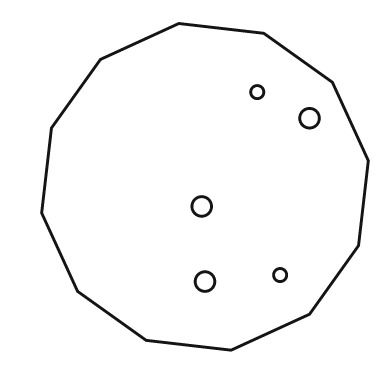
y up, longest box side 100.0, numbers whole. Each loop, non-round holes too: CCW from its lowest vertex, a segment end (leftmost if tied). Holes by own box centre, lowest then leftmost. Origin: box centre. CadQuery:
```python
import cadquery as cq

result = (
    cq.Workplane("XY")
    .moveTo(8.0, -50.0)
    .lineTo(32.0, -39.0)
    .lineTo(47.0, -18.0)
    .lineTo(50.0, 8.0)
    .lineTo(39.0, 32.0)
    .lineTo(18.0, 47.0)
    .lineTo(-8.0, 50.0)
    .lineTo(-32.0, 39.0)
    .lineTo(-47.0, 18.0)
    .lineTo(-50.0, -8.0)
    .lineTo(-39.0, -32.0)
    .lineTo(-18.0, -47.0)
    .close()
    .moveTo(0.0, -29.0)
    .circle(3.0)
    .moveTo(23.0, -27.0)
    .circle(2.0)
    .moveTo(-1.0, -6.0)
    .circle(3.0)
    .moveTo(32.0, 21.0)
    .circle(3.0)
    .moveTo(16.0, 29.0)
    .circle(2.0)
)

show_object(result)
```